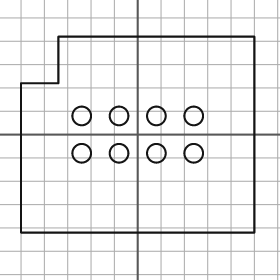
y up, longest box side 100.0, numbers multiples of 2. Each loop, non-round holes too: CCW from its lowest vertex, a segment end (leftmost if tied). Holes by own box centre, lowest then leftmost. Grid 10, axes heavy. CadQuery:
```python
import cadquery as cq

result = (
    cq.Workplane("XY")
    .moveTo(-50.0, -42.0)
    .lineTo(50.0, -42.0)
    .lineTo(50.0, 42.0)
    .lineTo(-34.0, 42.0)
    .lineTo(-34.0, 22.0)
    .lineTo(-50.0, 22.0)
    .close()
    .moveTo(-24.0, -8.0)
    .circle(4.0)
    .moveTo(-8.0, -8.0)
    .circle(4.0)
    .moveTo(8.0, -8.0)
    .circle(4.0)
    .moveTo(24.0, -8.0)
    .circle(4.0)
    .moveTo(-24.0, 8.0)
    .circle(4.0)
    .moveTo(-8.0, 8.0)
    .circle(4.0)
    .moveTo(8.0, 8.0)
    .circle(4.0)
    .moveTo(24.0, 8.0)
    .circle(4.0)
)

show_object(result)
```